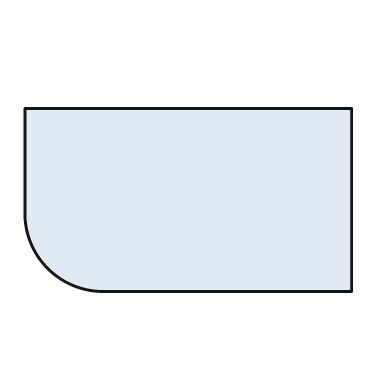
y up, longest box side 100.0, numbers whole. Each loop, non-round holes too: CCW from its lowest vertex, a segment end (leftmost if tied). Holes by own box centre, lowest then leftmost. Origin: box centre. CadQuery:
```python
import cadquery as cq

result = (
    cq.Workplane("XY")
    .moveTo(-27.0, -28.0)
    .lineTo(50.0, -28.0)
    .lineTo(50.0, 28.0)
    .lineTo(-50.0, 28.0)
    .lineTo(-50.0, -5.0)
    .threePointArc((-43.0, -21.0), (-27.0, -28.0))
    .close()
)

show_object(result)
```